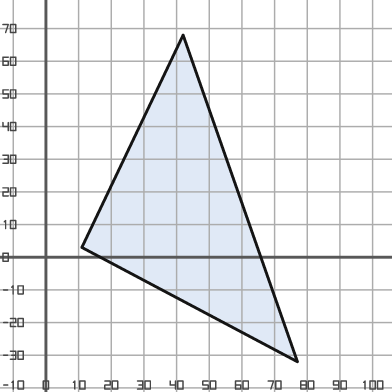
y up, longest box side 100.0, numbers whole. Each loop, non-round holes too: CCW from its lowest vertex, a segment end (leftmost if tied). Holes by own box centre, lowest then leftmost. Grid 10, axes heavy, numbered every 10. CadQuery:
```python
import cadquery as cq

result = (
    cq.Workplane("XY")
    .moveTo(77.0, -32.0)
    .lineTo(42.0, 68.0)
    .lineTo(11.0, 3.0)
    .close()
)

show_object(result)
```